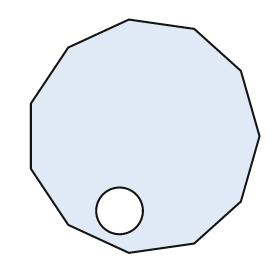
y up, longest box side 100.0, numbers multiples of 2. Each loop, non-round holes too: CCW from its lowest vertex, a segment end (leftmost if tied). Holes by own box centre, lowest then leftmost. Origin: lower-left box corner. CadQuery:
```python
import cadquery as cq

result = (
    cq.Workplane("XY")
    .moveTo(42.0, 0.0)
    .lineTo(70.0, 4.0)
    .lineTo(90.0, 22.0)
    .lineTo(98.0, 50.0)
    .lineTo(90.0, 78.0)
    .lineTo(70.0, 96.0)
    .lineTo(42.0, 100.0)
    .lineTo(16.0, 88.0)
    .lineTo(0.0, 64.0)
    .lineTo(0.0, 36.0)
    .lineTo(16.0, 12.0)
    .close()
    .moveTo(38.0, 18.0)
    .circle(10.0)
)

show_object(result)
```